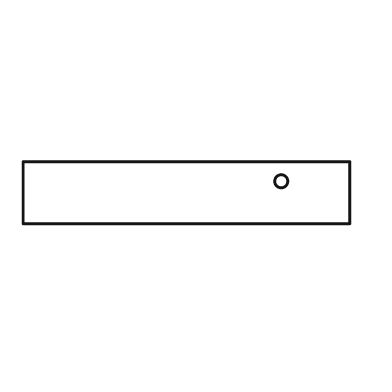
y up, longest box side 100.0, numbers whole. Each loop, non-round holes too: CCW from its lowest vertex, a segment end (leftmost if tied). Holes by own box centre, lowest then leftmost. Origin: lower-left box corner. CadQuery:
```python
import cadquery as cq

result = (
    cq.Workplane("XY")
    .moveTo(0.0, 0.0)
    .lineTo(100.0, 0.0)
    .lineTo(100.0, 19.0)
    .lineTo(0.0, 19.0)
    .close()
    .moveTo(79.0, 13.0)
    .circle(2.0)
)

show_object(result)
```